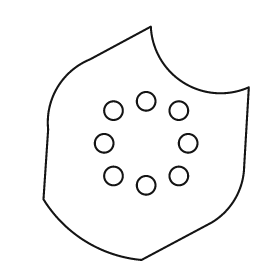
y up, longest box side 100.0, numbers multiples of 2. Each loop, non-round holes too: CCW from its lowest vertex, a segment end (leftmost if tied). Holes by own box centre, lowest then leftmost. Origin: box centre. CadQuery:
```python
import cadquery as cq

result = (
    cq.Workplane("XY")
    .moveTo(-2.0, -50.0)
    .lineTo(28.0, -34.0)
    .threePointArc((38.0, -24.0), (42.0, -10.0))
    .lineTo(44.0, 24.0)
    .threePointArc((16.0, 26.0), (2.0, 50.0))
    .lineTo(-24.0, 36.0)
    .threePointArc((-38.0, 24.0), (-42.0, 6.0))
    .lineTo(-44.0, -24.0)
    .threePointArc((-26.0, -42.0), (-2.0, -50.0))
    .close()
    .moveTo(0.0, -18.0)
    .circle(4.0)
    .moveTo(-14.0, -14.0)
    .circle(4.0)
    .moveTo(14.0, -14.0)
    .circle(4.0)
    .moveTo(-18.0, 0.0)
    .circle(4.0)
    .moveTo(18.0, 0.0)
    .circle(4.0)
    .moveTo(-14.0, 14.0)
    .circle(4.0)
    .moveTo(14.0, 14.0)
    .circle(4.0)
    .moveTo(0.0, 18.0)
    .circle(4.0)
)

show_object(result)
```